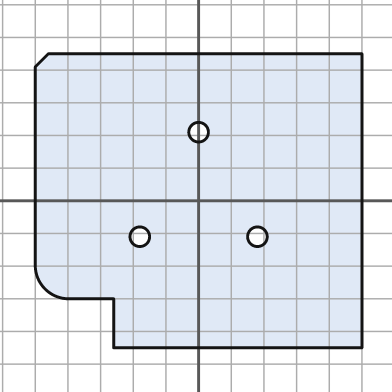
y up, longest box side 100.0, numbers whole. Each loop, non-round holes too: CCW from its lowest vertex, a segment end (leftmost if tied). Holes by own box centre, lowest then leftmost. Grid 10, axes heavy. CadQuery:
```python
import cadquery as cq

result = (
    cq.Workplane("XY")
    .moveTo(-26.0, -45.0)
    .lineTo(50.0, -45.0)
    .lineTo(50.0, 45.0)
    .lineTo(-46.0, 45.0)
    .lineTo(-50.0, 41.0)
    .lineTo(-50.0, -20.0)
    .threePointArc((-47.0, -27.0), (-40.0, -30.0))
    .lineTo(-26.0, -30.0)
    .close()
    .moveTo(-18.0, -11.0)
    .circle(3.0)
    .moveTo(18.0, -11.0)
    .circle(3.0)
    .moveTo(0.0, 21.0)
    .circle(3.0)
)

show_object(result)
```